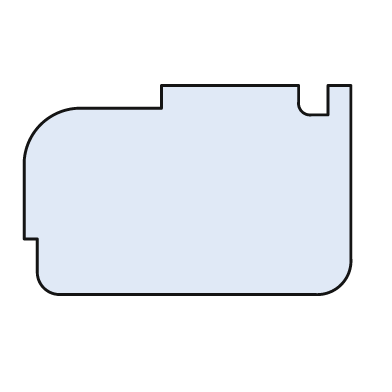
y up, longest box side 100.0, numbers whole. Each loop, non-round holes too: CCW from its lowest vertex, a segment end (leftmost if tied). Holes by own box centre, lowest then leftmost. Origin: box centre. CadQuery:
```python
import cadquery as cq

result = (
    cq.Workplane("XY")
    .moveTo(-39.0, -32.0)
    .lineTo(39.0, -32.0)
    .threePointArc((47.0, -29.0), (50.0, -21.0))
    .lineTo(50.0, 32.0)
    .lineTo(43.0, 32.0)
    .lineTo(43.0, 23.0)
    .lineTo(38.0, 23.0)
    .threePointArc((35.0, 24.0), (34.0, 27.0))
    .lineTo(34.0, 32.0)
    .lineTo(-8.0, 32.0)
    .lineTo(-8.0, 25.0)
    .lineTo(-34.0, 25.0)
    .threePointArc((-45.0, 20.0), (-50.0, 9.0))
    .lineTo(-50.0, -15.0)
    .lineTo(-46.0, -15.0)
    .lineTo(-46.0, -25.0)
    .threePointArc((-44.0, -30.0), (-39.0, -32.0))
    .close()
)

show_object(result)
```